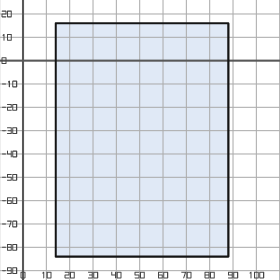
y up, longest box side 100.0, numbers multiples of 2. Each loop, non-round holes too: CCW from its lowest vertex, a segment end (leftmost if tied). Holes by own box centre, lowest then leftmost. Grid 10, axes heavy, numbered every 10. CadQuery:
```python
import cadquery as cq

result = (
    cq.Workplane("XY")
    .moveTo(14.0, -84.0)
    .lineTo(88.0, -84.0)
    .lineTo(88.0, 16.0)
    .lineTo(14.0, 16.0)
    .close()
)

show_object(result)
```